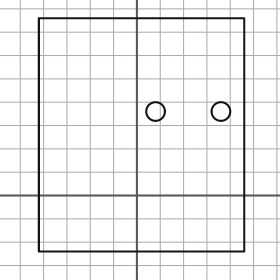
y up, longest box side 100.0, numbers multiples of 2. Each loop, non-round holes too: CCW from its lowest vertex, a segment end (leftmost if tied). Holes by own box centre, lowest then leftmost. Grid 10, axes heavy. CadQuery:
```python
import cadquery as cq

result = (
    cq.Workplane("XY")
    .moveTo(-42.0, -24.0)
    .lineTo(46.0, -24.0)
    .lineTo(46.0, 76.0)
    .lineTo(-42.0, 76.0)
    .close()
    .moveTo(8.0, 36.0)
    .circle(4.0)
    .moveTo(36.0, 36.0)
    .circle(4.0)
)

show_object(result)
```